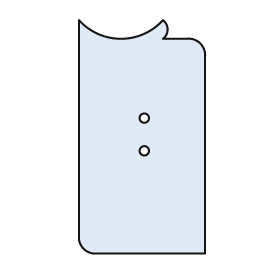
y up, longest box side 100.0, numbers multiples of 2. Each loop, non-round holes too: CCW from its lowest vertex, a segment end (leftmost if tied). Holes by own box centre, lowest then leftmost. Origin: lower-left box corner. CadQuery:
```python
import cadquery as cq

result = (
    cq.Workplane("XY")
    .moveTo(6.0, 0.0)
    .lineTo(54.0, 0.0)
    .lineTo(54.0, 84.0)
    .threePointArc((52.0, 90.0), (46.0, 92.0))
    .lineTo(36.0, 92.0)
    .threePointArc((38.0, 96.0), (36.0, 100.0))
    .threePointArc((18.0, 92.0), (0.0, 100.0))
    .lineTo(0.0, 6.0)
    .threePointArc((2.0, 2.0), (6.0, 0.0))
    .close()
    .moveTo(28.0, 44.0)
    .circle(2.0)
    .moveTo(28.0, 58.0)
    .circle(2.0)
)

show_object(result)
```